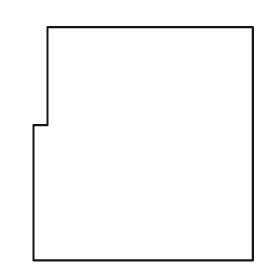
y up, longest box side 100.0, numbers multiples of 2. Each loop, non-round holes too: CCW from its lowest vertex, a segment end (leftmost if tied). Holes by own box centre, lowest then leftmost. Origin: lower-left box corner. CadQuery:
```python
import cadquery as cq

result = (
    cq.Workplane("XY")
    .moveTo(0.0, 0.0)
    .lineTo(94.0, 0.0)
    .lineTo(94.0, 100.0)
    .lineTo(6.0, 100.0)
    .lineTo(6.0, 58.0)
    .lineTo(0.0, 58.0)
    .close()
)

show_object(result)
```